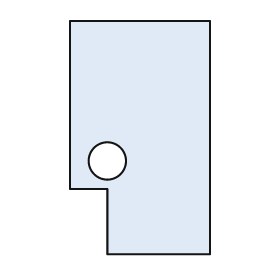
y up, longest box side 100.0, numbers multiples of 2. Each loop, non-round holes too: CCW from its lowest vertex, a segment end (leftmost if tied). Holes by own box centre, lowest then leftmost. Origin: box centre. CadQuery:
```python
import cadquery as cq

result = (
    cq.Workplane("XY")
    .moveTo(-14.0, -50.0)
    .lineTo(30.0, -50.0)
    .lineTo(30.0, 50.0)
    .lineTo(-30.0, 50.0)
    .lineTo(-30.0, -22.0)
    .lineTo(-14.0, -22.0)
    .close()
    .moveTo(-14.0, -10.0)
    .circle(8.0)
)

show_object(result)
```